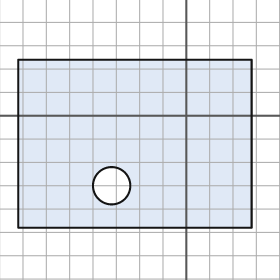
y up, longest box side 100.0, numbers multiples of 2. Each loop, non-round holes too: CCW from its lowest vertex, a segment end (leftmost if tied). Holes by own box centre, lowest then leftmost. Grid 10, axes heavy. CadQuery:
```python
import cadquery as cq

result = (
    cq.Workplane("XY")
    .moveTo(-72.0, -48.0)
    .lineTo(28.0, -48.0)
    .lineTo(28.0, 24.0)
    .lineTo(-72.0, 24.0)
    .close()
    .moveTo(-32.0, -30.0)
    .circle(8.0)
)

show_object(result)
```